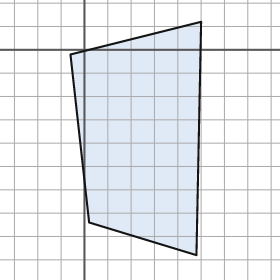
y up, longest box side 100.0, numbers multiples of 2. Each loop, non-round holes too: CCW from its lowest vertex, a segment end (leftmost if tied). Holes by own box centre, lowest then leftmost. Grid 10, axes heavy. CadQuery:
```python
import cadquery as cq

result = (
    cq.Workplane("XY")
    .moveTo(48.0, -88.0)
    .lineTo(50.0, 12.0)
    .lineTo(-6.0, -2.0)
    .lineTo(2.0, -74.0)
    .close()
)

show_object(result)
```